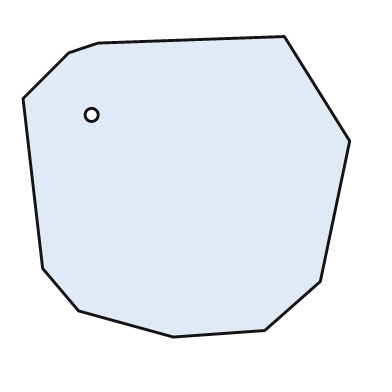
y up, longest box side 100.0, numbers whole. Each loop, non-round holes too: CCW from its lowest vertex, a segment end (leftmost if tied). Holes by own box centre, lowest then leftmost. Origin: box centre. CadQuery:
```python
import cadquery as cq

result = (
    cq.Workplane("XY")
    .moveTo(-4.0, -46.0)
    .lineTo(24.0, -44.0)
    .lineTo(41.0, -29.0)
    .lineTo(50.0, 14.0)
    .lineTo(30.0, 46.0)
    .lineTo(-27.0, 44.0)
    .lineTo(-36.0, 41.0)
    .lineTo(-50.0, 27.0)
    .lineTo(-44.0, -25.0)
    .lineTo(-33.0, -38.0)
    .close()
    .moveTo(-29.0, 22.0)
    .circle(2.0)
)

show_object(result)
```